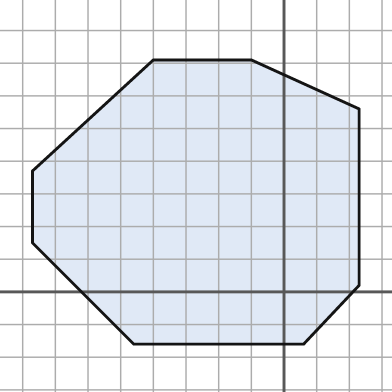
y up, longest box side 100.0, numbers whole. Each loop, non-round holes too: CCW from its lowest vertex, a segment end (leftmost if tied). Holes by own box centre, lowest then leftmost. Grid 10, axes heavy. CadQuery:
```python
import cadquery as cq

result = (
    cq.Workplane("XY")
    .moveTo(-46.0, -16.0)
    .lineTo(6.0, -16.0)
    .lineTo(23.0, 2.0)
    .lineTo(23.0, 56.0)
    .lineTo(-10.0, 71.0)
    .lineTo(-40.0, 71.0)
    .lineTo(-77.0, 37.0)
    .lineTo(-77.0, 15.0)
    .close()
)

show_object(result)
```